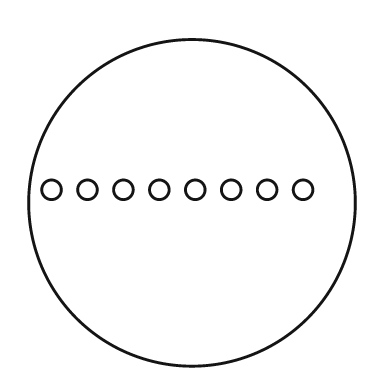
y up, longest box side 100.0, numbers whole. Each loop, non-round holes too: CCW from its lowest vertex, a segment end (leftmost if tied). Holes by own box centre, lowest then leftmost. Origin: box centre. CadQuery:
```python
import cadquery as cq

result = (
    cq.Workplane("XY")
    .moveTo(0.0, 0.0)
    .circle(50.0)
    .moveTo(-43.0, 4.0)
    .circle(3.0)
    .moveTo(-32.0, 4.0)
    .circle(3.0)
    .moveTo(-21.0, 4.0)
    .circle(3.0)
    .moveTo(-10.0, 4.0)
    .circle(3.0)
    .moveTo(1.0, 4.0)
    .circle(3.0)
    .moveTo(12.0, 4.0)
    .circle(3.0)
    .moveTo(23.0, 4.0)
    .circle(3.0)
    .moveTo(34.0, 4.0)
    .circle(3.0)
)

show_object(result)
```